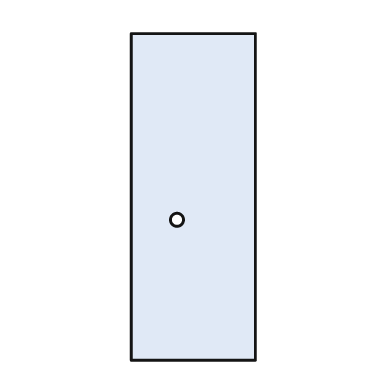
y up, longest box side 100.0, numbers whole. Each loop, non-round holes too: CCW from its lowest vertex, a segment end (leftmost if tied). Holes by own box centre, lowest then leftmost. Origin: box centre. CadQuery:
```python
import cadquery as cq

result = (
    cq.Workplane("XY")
    .moveTo(-19.0, -50.0)
    .lineTo(19.0, -50.0)
    .lineTo(19.0, 50.0)
    .lineTo(-19.0, 50.0)
    .close()
    .moveTo(-5.0, -7.0)
    .circle(2.0)
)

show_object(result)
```